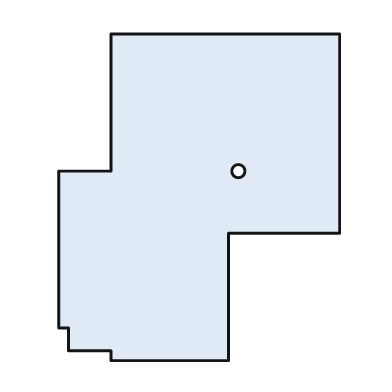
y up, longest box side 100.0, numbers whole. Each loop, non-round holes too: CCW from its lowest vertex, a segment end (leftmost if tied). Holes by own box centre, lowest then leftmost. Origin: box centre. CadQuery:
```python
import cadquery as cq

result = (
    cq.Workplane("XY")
    .moveTo(-27.0, -50.0)
    .lineTo(9.0, -50.0)
    .lineTo(9.0, -11.0)
    .lineTo(43.0, -11.0)
    .lineTo(43.0, 50.0)
    .lineTo(-27.0, 50.0)
    .lineTo(-27.0, 8.0)
    .lineTo(-43.0, 8.0)
    .lineTo(-43.0, -40.0)
    .lineTo(-40.0, -40.0)
    .lineTo(-40.0, -47.0)
    .lineTo(-27.0, -47.0)
    .close()
    .moveTo(12.0, 8.0)
    .circle(2.0)
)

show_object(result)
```